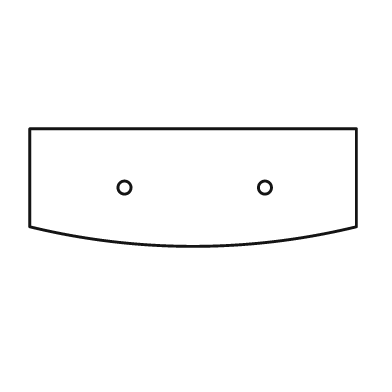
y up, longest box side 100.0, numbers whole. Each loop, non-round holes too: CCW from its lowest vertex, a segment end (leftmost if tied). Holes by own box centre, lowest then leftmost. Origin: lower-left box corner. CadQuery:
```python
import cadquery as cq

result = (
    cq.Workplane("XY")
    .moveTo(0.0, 6.0)
    .threePointArc((50.0, 0.0), (100.0, 6.0))
    .lineTo(100.0, 36.0)
    .lineTo(0.0, 36.0)
    .close()
    .moveTo(29.0, 18.0)
    .circle(2.0)
    .moveTo(72.0, 18.0)
    .circle(2.0)
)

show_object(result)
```